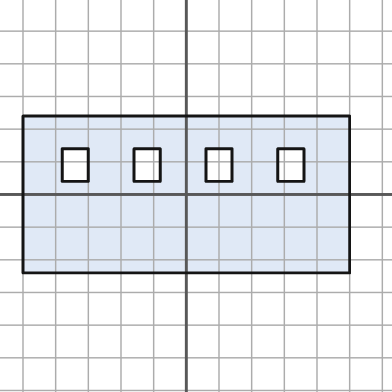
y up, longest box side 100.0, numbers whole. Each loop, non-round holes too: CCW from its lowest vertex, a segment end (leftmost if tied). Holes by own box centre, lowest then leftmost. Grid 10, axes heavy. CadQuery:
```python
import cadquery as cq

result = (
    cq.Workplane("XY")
    .moveTo(-50.0, -24.0)
    .lineTo(50.0, -24.0)
    .lineTo(50.0, 24.0)
    .lineTo(-50.0, 24.0)
    .close()
    .moveTo(-38.0, 4.0)
    .lineTo(-30.0, 4.0)
    .lineTo(-30.0, 14.0)
    .lineTo(-38.0, 14.0)
    .close()
    .moveTo(-16.0, 4.0)
    .lineTo(-8.0, 4.0)
    .lineTo(-8.0, 14.0)
    .lineTo(-16.0, 14.0)
    .close()
    .moveTo(6.0, 4.0)
    .lineTo(14.0, 4.0)
    .lineTo(14.0, 14.0)
    .lineTo(6.0, 14.0)
    .close()
    .moveTo(28.0, 4.0)
    .lineTo(36.0, 4.0)
    .lineTo(36.0, 14.0)
    .lineTo(28.0, 14.0)
    .close()
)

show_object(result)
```